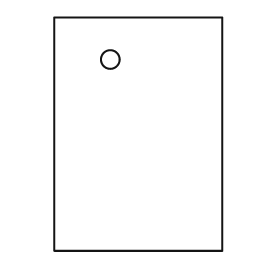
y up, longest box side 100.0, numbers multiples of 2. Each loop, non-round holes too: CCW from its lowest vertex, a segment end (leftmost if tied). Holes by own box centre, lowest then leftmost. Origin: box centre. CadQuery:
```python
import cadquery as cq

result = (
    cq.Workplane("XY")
    .moveTo(-36.0, -50.0)
    .lineTo(36.0, -50.0)
    .lineTo(36.0, 50.0)
    .lineTo(-36.0, 50.0)
    .close()
    .moveTo(-12.0, 32.0)
    .circle(4.0)
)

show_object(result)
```